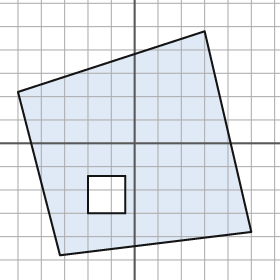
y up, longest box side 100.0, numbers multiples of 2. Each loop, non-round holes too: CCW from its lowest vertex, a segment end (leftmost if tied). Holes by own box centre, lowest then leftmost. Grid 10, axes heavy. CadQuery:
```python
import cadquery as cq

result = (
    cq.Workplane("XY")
    .moveTo(-32.0, -48.0)
    .lineTo(50.0, -38.0)
    .lineTo(30.0, 48.0)
    .lineTo(-50.0, 22.0)
    .close()
    .moveTo(-20.0, -30.0)
    .lineTo(-4.0, -30.0)
    .lineTo(-4.0, -14.0)
    .lineTo(-20.0, -14.0)
    .close()
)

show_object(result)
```